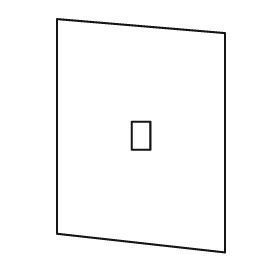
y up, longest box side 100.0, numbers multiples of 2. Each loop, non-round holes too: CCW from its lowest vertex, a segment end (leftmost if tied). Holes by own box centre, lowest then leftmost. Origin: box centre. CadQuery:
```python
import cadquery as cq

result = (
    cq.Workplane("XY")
    .moveTo(36.0, -50.0)
    .lineTo(36.0, 44.0)
    .lineTo(-36.0, 50.0)
    .lineTo(-36.0, -42.0)
    .close()
    .moveTo(-4.0, -6.0)
    .lineTo(4.0, -6.0)
    .lineTo(4.0, 6.0)
    .lineTo(-4.0, 6.0)
    .close()
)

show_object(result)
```